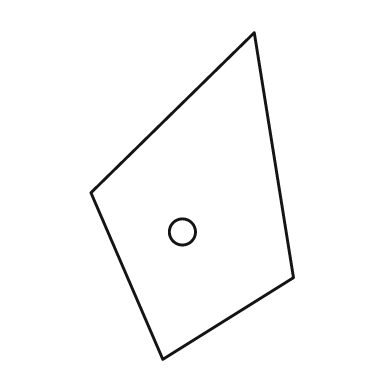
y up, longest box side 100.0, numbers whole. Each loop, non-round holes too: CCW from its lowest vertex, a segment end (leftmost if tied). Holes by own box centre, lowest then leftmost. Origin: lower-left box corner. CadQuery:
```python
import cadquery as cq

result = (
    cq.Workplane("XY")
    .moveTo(22.0, 0.0)
    .lineTo(62.0, 25.0)
    .lineTo(50.0, 100.0)
    .lineTo(0.0, 51.0)
    .close()
    .moveTo(28.0, 39.0)
    .circle(4.0)
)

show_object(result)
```